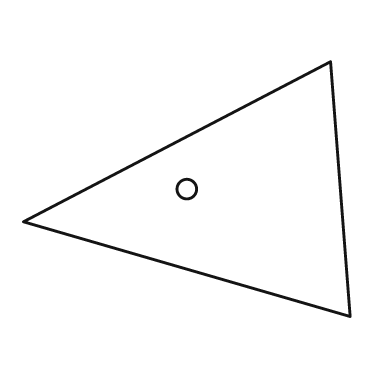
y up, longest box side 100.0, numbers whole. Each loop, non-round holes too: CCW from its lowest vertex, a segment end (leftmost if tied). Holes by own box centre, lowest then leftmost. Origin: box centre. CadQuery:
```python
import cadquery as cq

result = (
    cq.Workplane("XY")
    .moveTo(50.0, -39.0)
    .lineTo(44.0, 39.0)
    .lineTo(-50.0, -10.0)
    .close()
    .moveTo(0.0, 0.0)
    .circle(3.0)
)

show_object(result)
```